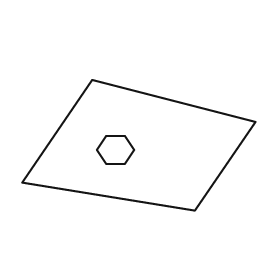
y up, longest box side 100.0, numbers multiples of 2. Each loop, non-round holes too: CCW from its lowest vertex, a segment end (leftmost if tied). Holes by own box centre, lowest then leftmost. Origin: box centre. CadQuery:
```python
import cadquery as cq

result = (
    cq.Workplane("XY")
    .moveTo(24.0, -28.0)
    .lineTo(50.0, 10.0)
    .lineTo(-20.0, 28.0)
    .lineTo(-50.0, -16.0)
    .close()
    .moveTo(-14.0, -8.0)
    .lineTo(-6.0, -8.0)
    .lineTo(-2.0, -2.0)
    .lineTo(-6.0, 4.0)
    .lineTo(-14.0, 4.0)
    .lineTo(-18.0, -2.0)
    .close()
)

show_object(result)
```